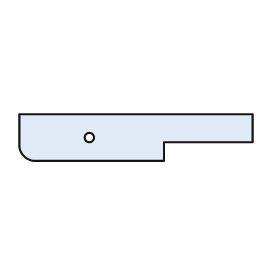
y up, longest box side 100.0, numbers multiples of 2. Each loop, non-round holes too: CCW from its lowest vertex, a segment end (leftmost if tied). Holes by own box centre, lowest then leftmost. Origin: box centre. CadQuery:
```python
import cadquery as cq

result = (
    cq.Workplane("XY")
    .moveTo(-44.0, -10.0)
    .lineTo(12.0, -10.0)
    .lineTo(12.0, -2.0)
    .lineTo(50.0, -2.0)
    .lineTo(50.0, 10.0)
    .lineTo(-50.0, 10.0)
    .lineTo(-50.0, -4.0)
    .threePointArc((-48.0, -8.0), (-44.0, -10.0))
    .close()
    .moveTo(-20.0, 0.0)
    .circle(2.0)
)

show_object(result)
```